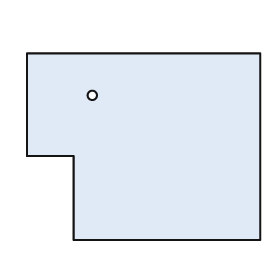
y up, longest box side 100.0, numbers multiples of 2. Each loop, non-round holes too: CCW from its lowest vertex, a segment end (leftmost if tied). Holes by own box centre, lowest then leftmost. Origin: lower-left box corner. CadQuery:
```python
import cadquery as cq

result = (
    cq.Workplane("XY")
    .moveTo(20.0, 0.0)
    .lineTo(100.0, 0.0)
    .lineTo(100.0, 80.0)
    .lineTo(0.0, 80.0)
    .lineTo(0.0, 36.0)
    .lineTo(20.0, 36.0)
    .close()
    .moveTo(28.0, 62.0)
    .circle(2.0)
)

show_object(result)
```